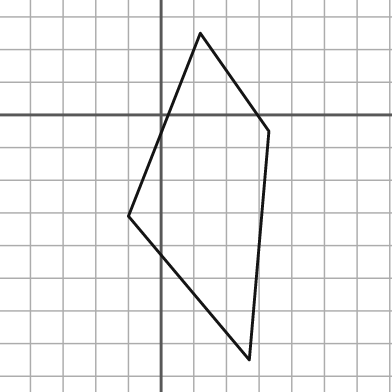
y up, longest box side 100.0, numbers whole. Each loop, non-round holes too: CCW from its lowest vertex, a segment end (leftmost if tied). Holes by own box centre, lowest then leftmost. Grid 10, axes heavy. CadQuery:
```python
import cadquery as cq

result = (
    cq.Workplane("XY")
    .moveTo(27.0, -75.0)
    .lineTo(33.0, -5.0)
    .lineTo(12.0, 25.0)
    .lineTo(-10.0, -31.0)
    .close()
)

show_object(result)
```